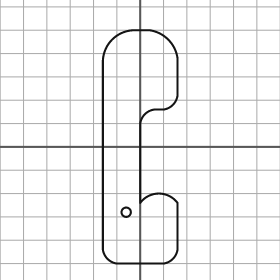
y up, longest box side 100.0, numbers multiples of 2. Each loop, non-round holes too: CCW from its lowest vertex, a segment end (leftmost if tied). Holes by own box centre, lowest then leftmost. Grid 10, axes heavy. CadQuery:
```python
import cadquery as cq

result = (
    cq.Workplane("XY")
    .moveTo(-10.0, -50.0)
    .lineTo(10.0, -50.0)
    .threePointArc((14.0, -48.0), (16.0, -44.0))
    .lineTo(16.0, -24.0)
    .threePointArc((8.0, -20.0), (0.0, -24.0))
    .lineTo(0.0, 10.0)
    .threePointArc((2.0, 14.0), (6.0, 16.0))
    .lineTo(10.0, 16.0)
    .threePointArc((14.0, 18.0), (16.0, 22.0))
    .lineTo(16.0, 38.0)
    .threePointArc((12.0, 46.0), (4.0, 50.0))
    .lineTo(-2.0, 50.0)
    .threePointArc((-12.0, 46.0), (-16.0, 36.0))
    .lineTo(-16.0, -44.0)
    .threePointArc((-14.0, -48.0), (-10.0, -50.0))
    .close()
    .moveTo(-6.0, -28.0)
    .circle(2.0)
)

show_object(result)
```